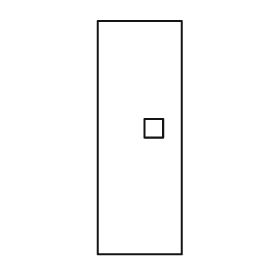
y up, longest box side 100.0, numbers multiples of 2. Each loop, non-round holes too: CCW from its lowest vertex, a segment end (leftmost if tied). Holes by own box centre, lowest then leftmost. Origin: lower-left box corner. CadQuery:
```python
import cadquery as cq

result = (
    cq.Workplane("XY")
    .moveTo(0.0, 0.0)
    .lineTo(36.0, 0.0)
    .lineTo(36.0, 100.0)
    .lineTo(0.0, 100.0)
    .close()
    .moveTo(20.0, 50.0)
    .lineTo(28.0, 50.0)
    .lineTo(28.0, 58.0)
    .lineTo(20.0, 58.0)
    .close()
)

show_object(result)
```